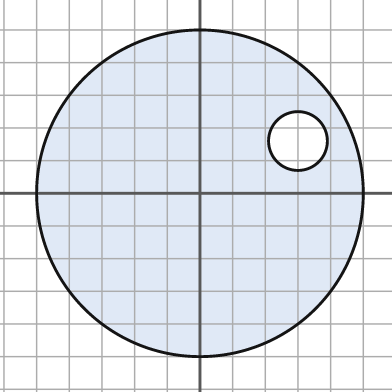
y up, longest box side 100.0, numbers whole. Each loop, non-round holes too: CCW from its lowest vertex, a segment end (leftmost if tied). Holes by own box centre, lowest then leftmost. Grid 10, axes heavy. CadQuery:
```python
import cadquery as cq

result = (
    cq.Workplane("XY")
    .moveTo(0.0, 0.0)
    .circle(50.0)
    .moveTo(30.0, 16.0)
    .circle(9.0)
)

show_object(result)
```